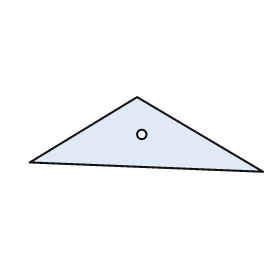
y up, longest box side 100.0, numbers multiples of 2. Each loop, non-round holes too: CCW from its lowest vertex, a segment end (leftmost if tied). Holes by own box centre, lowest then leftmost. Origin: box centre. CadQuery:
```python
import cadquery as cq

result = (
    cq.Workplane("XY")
    .moveTo(50.0, -16.0)
    .lineTo(-4.0, 16.0)
    .lineTo(-50.0, -12.0)
    .close()
    .moveTo(-2.0, 0.0)
    .circle(2.0)
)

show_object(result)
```